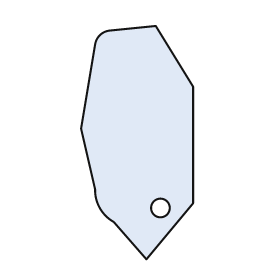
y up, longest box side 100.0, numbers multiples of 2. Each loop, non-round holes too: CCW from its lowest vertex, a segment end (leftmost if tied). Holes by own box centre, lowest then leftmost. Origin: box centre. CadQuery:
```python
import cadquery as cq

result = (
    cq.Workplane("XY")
    .moveTo(4.0, -50.0)
    .lineTo(24.0, -26.0)
    .lineTo(24.0, 24.0)
    .lineTo(8.0, 50.0)
    .lineTo(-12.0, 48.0)
    .threePointArc((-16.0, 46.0), (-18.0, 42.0))
    .lineTo(-24.0, 6.0)
    .lineTo(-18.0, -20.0)
    .threePointArc((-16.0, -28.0), (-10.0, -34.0))
    .close()
    .moveTo(10.0, -28.0)
    .circle(4.0)
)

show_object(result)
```